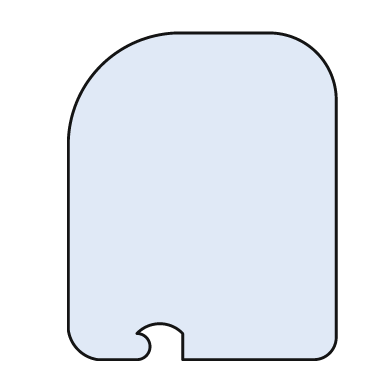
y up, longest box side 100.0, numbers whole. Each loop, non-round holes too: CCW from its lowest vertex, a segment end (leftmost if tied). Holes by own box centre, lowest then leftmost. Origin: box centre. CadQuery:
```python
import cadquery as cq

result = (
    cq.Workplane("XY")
    .moveTo(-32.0, -50.0)
    .lineTo(-20.0, -50.0)
    .threePointArc((-16.0, -46.0), (-20.0, -42.0))
    .threePointArc((-13.0, -39.0), (-6.0, -42.0))
    .lineTo(-6.0, -50.0)
    .lineTo(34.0, -50.0)
    .threePointArc((39.0, -48.0), (41.0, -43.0))
    .lineTo(41.0, 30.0)
    .threePointArc((35.0, 44.0), (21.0, 50.0))
    .lineTo(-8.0, 50.0)
    .threePointArc((-31.0, 40.0), (-41.0, 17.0))
    .lineTo(-41.0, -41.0)
    .threePointArc((-38.0, -47.0), (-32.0, -50.0))
    .close()
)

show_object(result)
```